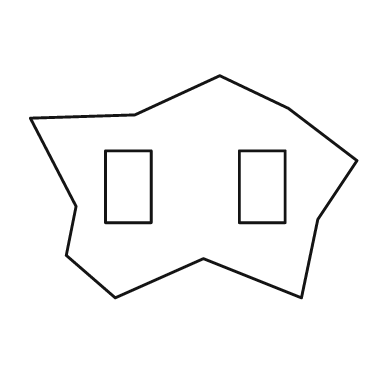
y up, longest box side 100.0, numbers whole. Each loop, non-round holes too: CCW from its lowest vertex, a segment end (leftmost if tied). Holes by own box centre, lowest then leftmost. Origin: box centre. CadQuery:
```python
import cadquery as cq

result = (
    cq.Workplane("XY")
    .moveTo(-24.0, -34.0)
    .lineTo(3.0, -22.0)
    .lineTo(33.0, -34.0)
    .lineTo(38.0, -10.0)
    .lineTo(50.0, 8.0)
    .lineTo(29.0, 24.0)
    .lineTo(8.0, 34.0)
    .lineTo(-18.0, 22.0)
    .lineTo(-50.0, 21.0)
    .lineTo(-36.0, -6.0)
    .lineTo(-39.0, -21.0)
    .close()
    .moveTo(-27.0, -11.0)
    .lineTo(-13.0, -11.0)
    .lineTo(-13.0, 11.0)
    .lineTo(-27.0, 11.0)
    .close()
    .moveTo(14.0, -11.0)
    .lineTo(28.0, -11.0)
    .lineTo(28.0, 11.0)
    .lineTo(14.0, 11.0)
    .close()
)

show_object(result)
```